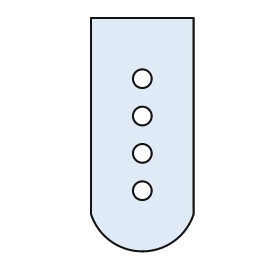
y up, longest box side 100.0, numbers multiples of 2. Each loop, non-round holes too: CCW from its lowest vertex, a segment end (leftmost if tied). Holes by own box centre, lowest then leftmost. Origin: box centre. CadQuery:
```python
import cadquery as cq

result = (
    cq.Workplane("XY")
    .moveTo(-22.0, -34.0)
    .threePointArc((0.0, -50.0), (22.0, -34.0))
    .lineTo(22.0, 50.0)
    .lineTo(-22.0, 50.0)
    .close()
    .moveTo(0.0, -24.0)
    .circle(4.0)
    .moveTo(0.0, -8.0)
    .circle(4.0)
    .moveTo(0.0, 8.0)
    .circle(4.0)
    .moveTo(0.0, 24.0)
    .circle(4.0)
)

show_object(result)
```